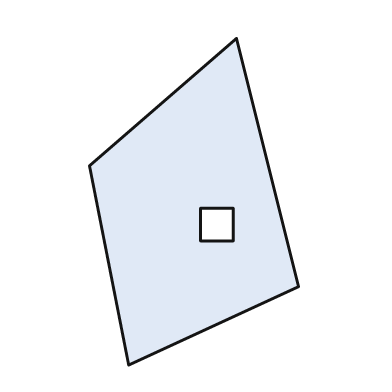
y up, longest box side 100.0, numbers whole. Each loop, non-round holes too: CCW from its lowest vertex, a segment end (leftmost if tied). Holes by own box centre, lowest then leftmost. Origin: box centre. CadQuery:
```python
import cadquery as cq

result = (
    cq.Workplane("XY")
    .moveTo(-20.0, -50.0)
    .lineTo(32.0, -26.0)
    .lineTo(13.0, 50.0)
    .lineTo(-32.0, 11.0)
    .close()
    .moveTo(2.0, -12.0)
    .lineTo(12.0, -12.0)
    .lineTo(12.0, -2.0)
    .lineTo(2.0, -2.0)
    .close()
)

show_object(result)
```